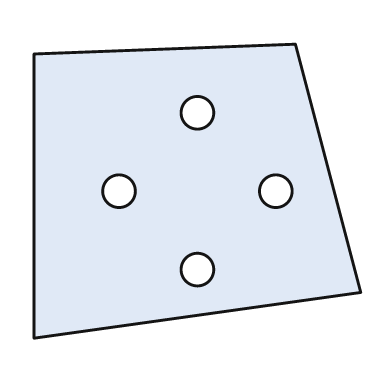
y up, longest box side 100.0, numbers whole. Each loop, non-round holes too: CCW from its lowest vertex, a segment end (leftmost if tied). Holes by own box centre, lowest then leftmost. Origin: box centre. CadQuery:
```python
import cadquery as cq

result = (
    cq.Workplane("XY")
    .moveTo(-50.0, -45.0)
    .lineTo(50.0, -31.0)
    .lineTo(30.0, 45.0)
    .lineTo(-50.0, 42.0)
    .close()
    .moveTo(0.0, -24.0)
    .circle(5.0)
    .moveTo(-24.0, 0.0)
    .circle(5.0)
    .moveTo(24.0, 0.0)
    .circle(5.0)
    .moveTo(0.0, 24.0)
    .circle(5.0)
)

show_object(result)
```